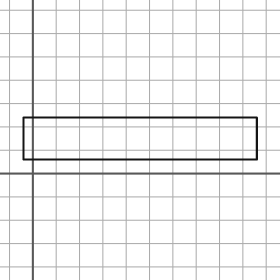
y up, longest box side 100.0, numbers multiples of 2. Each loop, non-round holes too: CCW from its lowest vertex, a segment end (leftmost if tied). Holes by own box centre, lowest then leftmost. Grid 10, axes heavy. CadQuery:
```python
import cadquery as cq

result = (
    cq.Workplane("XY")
    .moveTo(-4.0, 6.0)
    .lineTo(96.0, 6.0)
    .lineTo(96.0, 24.0)
    .lineTo(-4.0, 24.0)
    .close()
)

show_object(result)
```